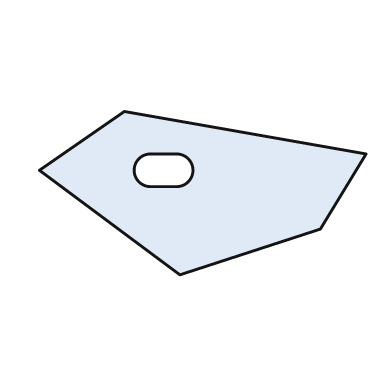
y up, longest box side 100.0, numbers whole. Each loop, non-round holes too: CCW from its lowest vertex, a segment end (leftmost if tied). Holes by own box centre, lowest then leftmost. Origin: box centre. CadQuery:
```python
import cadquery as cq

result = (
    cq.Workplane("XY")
    .moveTo(-7.0, -25.0)
    .lineTo(36.0, -11.0)
    .lineTo(50.0, 12.0)
    .lineTo(-24.0, 25.0)
    .lineTo(-50.0, 7.0)
    .close()
    .moveTo(-16.0, 2.0)
    .lineTo(-8.0, 2.0)
    .threePointArc((-3.0, 7.0), (-8.0, 12.0))
    .lineTo(-16.0, 12.0)
    .threePointArc((-21.0, 7.0), (-16.0, 2.0))
    .close()
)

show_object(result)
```